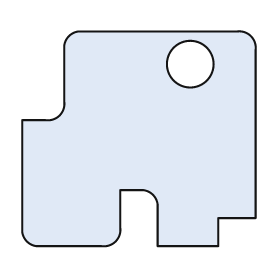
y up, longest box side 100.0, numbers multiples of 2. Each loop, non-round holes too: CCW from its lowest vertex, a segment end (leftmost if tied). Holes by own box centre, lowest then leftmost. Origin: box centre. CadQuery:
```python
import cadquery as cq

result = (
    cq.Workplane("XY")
    .moveTo(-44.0, -46.0)
    .lineTo(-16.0, -46.0)
    .threePointArc((-10.0, -44.0), (-8.0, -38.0))
    .lineTo(-8.0, -22.0)
    .lineTo(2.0, -22.0)
    .threePointArc((6.0, -24.0), (8.0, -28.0))
    .lineTo(8.0, -46.0)
    .lineTo(34.0, -46.0)
    .lineTo(34.0, -34.0)
    .lineTo(50.0, -34.0)
    .lineTo(50.0, 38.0)
    .threePointArc((48.0, 44.0), (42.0, 46.0))
    .lineTo(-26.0, 46.0)
    .threePointArc((-30.0, 44.0), (-32.0, 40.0))
    .lineTo(-32.0, 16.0)
    .threePointArc((-34.0, 10.0), (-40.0, 8.0))
    .lineTo(-50.0, 8.0)
    .lineTo(-50.0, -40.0)
    .threePointArc((-48.0, -44.0), (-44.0, -46.0))
    .close()
    .moveTo(22.0, 32.0)
    .circle(10.0)
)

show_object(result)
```